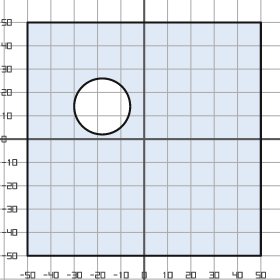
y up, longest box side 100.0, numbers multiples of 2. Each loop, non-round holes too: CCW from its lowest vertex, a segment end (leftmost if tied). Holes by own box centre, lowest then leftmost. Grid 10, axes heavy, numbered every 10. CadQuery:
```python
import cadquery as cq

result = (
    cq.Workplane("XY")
    .moveTo(-50.0, -50.0)
    .lineTo(50.0, -50.0)
    .lineTo(50.0, 50.0)
    .lineTo(-50.0, 50.0)
    .close()
    .moveTo(-18.0, 14.0)
    .circle(12.0)
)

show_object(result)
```